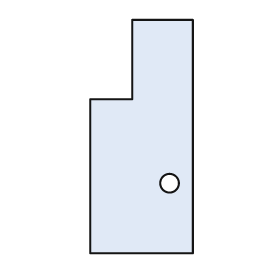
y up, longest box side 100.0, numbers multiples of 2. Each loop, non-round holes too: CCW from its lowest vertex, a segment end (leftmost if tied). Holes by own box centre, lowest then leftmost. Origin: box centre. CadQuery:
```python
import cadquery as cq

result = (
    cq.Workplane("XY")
    .moveTo(-22.0, -50.0)
    .lineTo(22.0, -50.0)
    .lineTo(22.0, 50.0)
    .lineTo(-4.0, 50.0)
    .lineTo(-4.0, 16.0)
    .lineTo(-22.0, 16.0)
    .close()
    .moveTo(12.0, -20.0)
    .circle(4.0)
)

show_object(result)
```